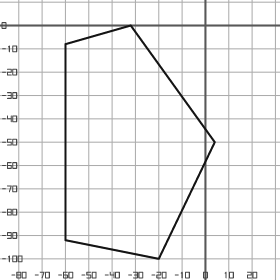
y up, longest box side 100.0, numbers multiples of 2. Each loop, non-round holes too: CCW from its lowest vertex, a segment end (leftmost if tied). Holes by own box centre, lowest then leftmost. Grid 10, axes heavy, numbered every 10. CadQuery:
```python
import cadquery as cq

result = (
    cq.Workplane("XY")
    .moveTo(-20.0, -100.0)
    .lineTo(4.0, -50.0)
    .lineTo(-32.0, 0.0)
    .lineTo(-60.0, -8.0)
    .lineTo(-60.0, -92.0)
    .close()
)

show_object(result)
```